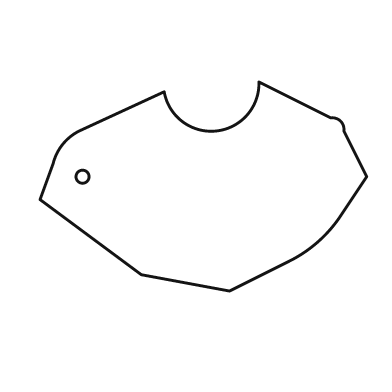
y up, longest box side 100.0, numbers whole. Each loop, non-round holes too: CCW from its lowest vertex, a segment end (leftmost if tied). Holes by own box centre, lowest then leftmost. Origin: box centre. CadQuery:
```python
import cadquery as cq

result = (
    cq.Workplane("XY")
    .moveTo(8.0, -32.0)
    .lineTo(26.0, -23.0)
    .threePointArc((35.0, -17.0), (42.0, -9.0))
    .lineTo(50.0, 3.0)
    .lineTo(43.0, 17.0)
    .threePointArc((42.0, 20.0), (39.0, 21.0))
    .lineTo(17.0, 32.0)
    .threePointArc((4.0, 17.0), (-12.0, 29.0))
    .lineTo(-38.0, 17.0)
    .threePointArc((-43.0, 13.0), (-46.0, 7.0))
    .lineTo(-50.0, -4.0)
    .lineTo(-19.0, -27.0)
    .close()
    .moveTo(-37.0, 3.0)
    .circle(2.0)
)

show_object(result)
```